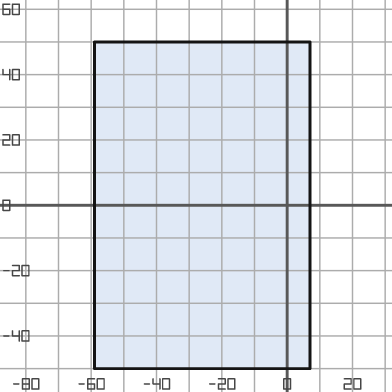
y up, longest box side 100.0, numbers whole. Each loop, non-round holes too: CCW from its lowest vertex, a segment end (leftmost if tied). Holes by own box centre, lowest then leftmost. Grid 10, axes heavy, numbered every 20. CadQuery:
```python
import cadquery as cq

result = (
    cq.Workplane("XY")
    .moveTo(-59.0, -50.0)
    .lineTo(7.0, -50.0)
    .lineTo(7.0, 50.0)
    .lineTo(-59.0, 50.0)
    .close()
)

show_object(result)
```